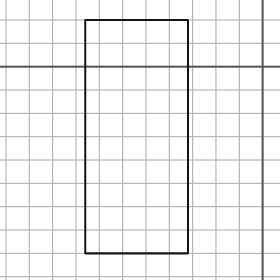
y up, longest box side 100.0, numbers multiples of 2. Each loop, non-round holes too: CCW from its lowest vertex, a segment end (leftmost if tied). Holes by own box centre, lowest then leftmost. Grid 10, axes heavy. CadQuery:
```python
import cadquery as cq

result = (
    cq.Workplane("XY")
    .moveTo(-76.0, -80.0)
    .lineTo(-32.0, -80.0)
    .lineTo(-32.0, 20.0)
    .lineTo(-76.0, 20.0)
    .close()
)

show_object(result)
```